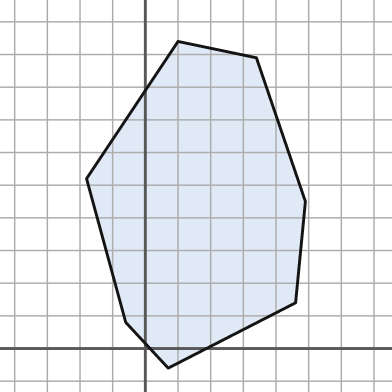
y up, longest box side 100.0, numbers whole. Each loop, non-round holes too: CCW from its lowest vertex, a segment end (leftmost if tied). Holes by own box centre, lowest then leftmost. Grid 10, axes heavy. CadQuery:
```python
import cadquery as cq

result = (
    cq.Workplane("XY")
    .moveTo(7.0, -6.0)
    .lineTo(46.0, 14.0)
    .lineTo(49.0, 45.0)
    .lineTo(34.0, 89.0)
    .lineTo(10.0, 94.0)
    .lineTo(-18.0, 52.0)
    .lineTo(-6.0, 8.0)
    .close()
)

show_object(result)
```